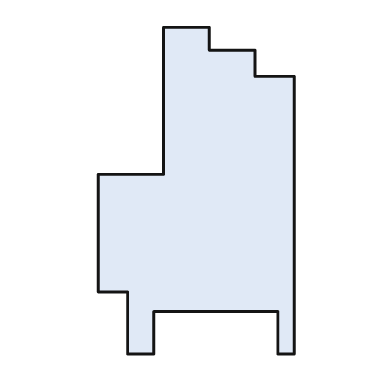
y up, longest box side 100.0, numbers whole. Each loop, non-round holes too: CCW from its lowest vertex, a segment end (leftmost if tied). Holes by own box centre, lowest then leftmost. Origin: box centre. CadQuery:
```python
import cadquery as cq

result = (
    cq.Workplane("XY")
    .moveTo(-21.0, -50.0)
    .lineTo(-13.0, -50.0)
    .lineTo(-13.0, -37.0)
    .lineTo(25.0, -37.0)
    .lineTo(25.0, -50.0)
    .lineTo(30.0, -50.0)
    .lineTo(30.0, 35.0)
    .lineTo(18.0, 35.0)
    .lineTo(18.0, 43.0)
    .lineTo(4.0, 43.0)
    .lineTo(4.0, 50.0)
    .lineTo(-10.0, 50.0)
    .lineTo(-10.0, 5.0)
    .lineTo(-30.0, 5.0)
    .lineTo(-30.0, -31.0)
    .lineTo(-21.0, -31.0)
    .close()
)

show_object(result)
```